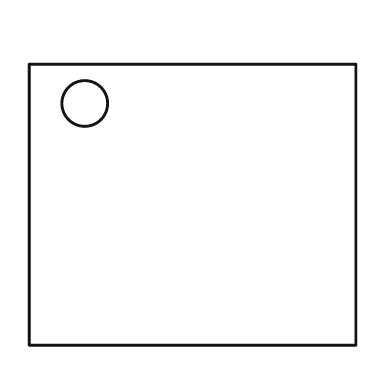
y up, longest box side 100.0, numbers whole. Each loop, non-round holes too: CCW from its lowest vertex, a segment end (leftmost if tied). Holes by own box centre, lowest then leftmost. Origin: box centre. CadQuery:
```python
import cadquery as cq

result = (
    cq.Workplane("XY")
    .moveTo(-50.0, -43.0)
    .lineTo(50.0, -43.0)
    .lineTo(50.0, 43.0)
    .lineTo(-50.0, 43.0)
    .close()
    .moveTo(-33.0, 31.0)
    .circle(7.0)
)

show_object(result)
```